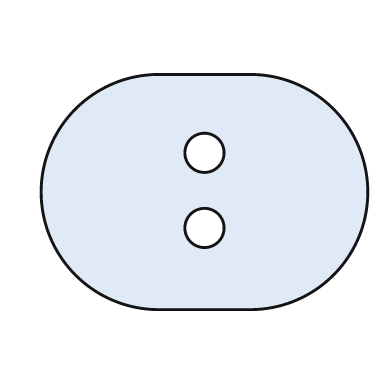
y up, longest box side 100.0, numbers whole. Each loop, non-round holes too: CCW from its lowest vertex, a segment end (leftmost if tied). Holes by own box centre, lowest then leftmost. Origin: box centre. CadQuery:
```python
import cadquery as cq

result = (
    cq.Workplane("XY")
    .moveTo(-14.0, -36.0)
    .lineTo(14.0, -36.0)
    .threePointArc((50.0, 0.0), (14.0, 36.0))
    .lineTo(-14.0, 36.0)
    .threePointArc((-50.0, 0.0), (-14.0, -36.0))
    .close()
    .moveTo(0.0, -11.0)
    .circle(6.0)
    .moveTo(0.0, 12.0)
    .circle(6.0)
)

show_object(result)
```